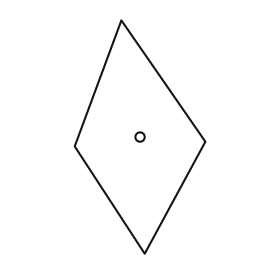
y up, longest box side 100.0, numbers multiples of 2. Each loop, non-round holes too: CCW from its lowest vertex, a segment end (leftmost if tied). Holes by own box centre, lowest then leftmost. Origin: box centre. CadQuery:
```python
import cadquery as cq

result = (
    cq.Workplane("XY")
    .moveTo(2.0, -50.0)
    .lineTo(28.0, -2.0)
    .lineTo(-8.0, 50.0)
    .lineTo(-28.0, -4.0)
    .close()
    .moveTo(0.0, 0.0)
    .circle(2.0)
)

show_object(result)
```